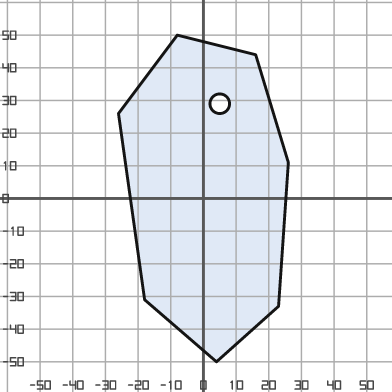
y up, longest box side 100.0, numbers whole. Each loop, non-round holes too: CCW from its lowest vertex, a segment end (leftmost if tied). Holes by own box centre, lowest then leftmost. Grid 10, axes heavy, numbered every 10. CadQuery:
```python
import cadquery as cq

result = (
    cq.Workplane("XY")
    .moveTo(4.0, -50.0)
    .lineTo(23.0, -33.0)
    .lineTo(26.0, 11.0)
    .lineTo(16.0, 44.0)
    .lineTo(-8.0, 50.0)
    .lineTo(-26.0, 26.0)
    .lineTo(-18.0, -31.0)
    .close()
    .moveTo(5.0, 29.0)
    .circle(3.0)
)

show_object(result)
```